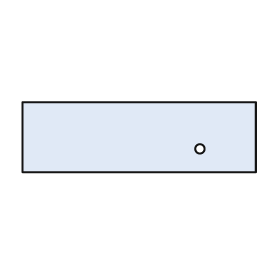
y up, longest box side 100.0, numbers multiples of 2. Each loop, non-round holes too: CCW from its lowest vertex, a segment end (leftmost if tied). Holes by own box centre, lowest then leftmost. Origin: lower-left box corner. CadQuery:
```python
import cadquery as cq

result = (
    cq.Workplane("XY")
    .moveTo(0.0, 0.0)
    .lineTo(100.0, 0.0)
    .lineTo(100.0, 30.0)
    .lineTo(0.0, 30.0)
    .close()
    .moveTo(76.0, 10.0)
    .circle(2.0)
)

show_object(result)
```